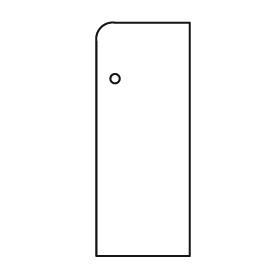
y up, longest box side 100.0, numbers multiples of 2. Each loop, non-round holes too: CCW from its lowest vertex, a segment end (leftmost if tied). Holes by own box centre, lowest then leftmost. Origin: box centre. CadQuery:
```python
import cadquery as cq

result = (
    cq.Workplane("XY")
    .moveTo(-20.0, -50.0)
    .lineTo(20.0, -50.0)
    .lineTo(20.0, 50.0)
    .lineTo(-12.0, 50.0)
    .threePointArc((-18.0, 48.0), (-20.0, 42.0))
    .close()
    .moveTo(-12.0, 26.0)
    .circle(2.0)
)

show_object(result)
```